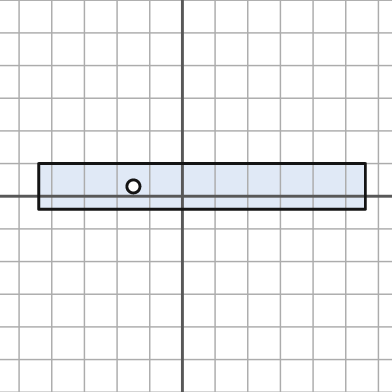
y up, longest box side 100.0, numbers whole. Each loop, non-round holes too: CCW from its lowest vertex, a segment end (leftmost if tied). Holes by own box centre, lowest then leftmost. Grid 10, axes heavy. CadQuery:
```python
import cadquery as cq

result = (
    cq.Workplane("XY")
    .moveTo(-44.0, -4.0)
    .lineTo(56.0, -4.0)
    .lineTo(56.0, 10.0)
    .lineTo(-44.0, 10.0)
    .close()
    .moveTo(-15.0, 3.0)
    .circle(2.0)
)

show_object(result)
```